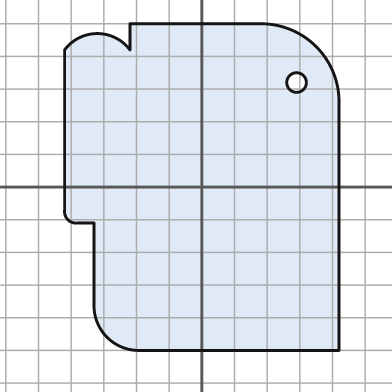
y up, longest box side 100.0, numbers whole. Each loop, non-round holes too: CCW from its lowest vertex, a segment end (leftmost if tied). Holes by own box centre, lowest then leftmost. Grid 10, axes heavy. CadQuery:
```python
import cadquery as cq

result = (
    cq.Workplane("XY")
    .moveTo(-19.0, -50.0)
    .lineTo(42.0, -50.0)
    .lineTo(42.0, 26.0)
    .threePointArc((35.0, 43.0), (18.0, 50.0))
    .lineTo(-22.0, 50.0)
    .lineTo(-22.0, 42.0)
    .threePointArc((-32.0, 47.0), (-42.0, 42.0))
    .lineTo(-42.0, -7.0)
    .threePointArc((-41.0, -10.0), (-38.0, -11.0))
    .lineTo(-33.0, -11.0)
    .lineTo(-33.0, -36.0)
    .threePointArc((-29.0, -46.0), (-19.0, -50.0))
    .close()
    .moveTo(29.0, 32.0)
    .circle(3.0)
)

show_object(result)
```